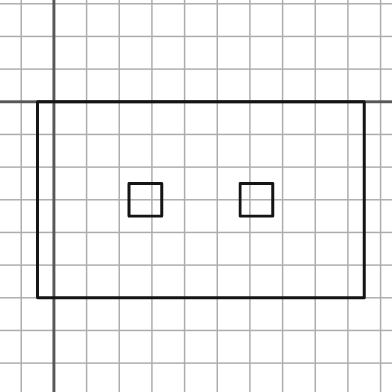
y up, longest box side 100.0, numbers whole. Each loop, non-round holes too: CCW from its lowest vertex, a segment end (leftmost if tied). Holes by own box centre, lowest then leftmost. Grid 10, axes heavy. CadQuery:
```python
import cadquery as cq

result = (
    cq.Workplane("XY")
    .moveTo(-5.0, -60.0)
    .lineTo(95.0, -60.0)
    .lineTo(95.0, 0.0)
    .lineTo(-5.0, 0.0)
    .close()
    .moveTo(23.0, -35.0)
    .lineTo(33.0, -35.0)
    .lineTo(33.0, -25.0)
    .lineTo(23.0, -25.0)
    .close()
    .moveTo(57.0, -35.0)
    .lineTo(67.0, -35.0)
    .lineTo(67.0, -25.0)
    .lineTo(57.0, -25.0)
    .close()
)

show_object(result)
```